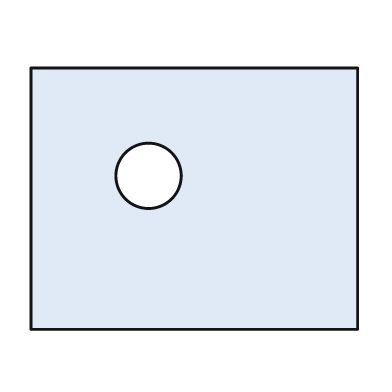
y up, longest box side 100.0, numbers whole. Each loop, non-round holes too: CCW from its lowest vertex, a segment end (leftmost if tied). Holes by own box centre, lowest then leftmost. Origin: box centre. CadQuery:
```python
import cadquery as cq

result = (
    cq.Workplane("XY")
    .moveTo(-50.0, -40.0)
    .lineTo(50.0, -40.0)
    .lineTo(50.0, 40.0)
    .lineTo(-50.0, 40.0)
    .close()
    .moveTo(-14.0, 7.0)
    .circle(10.0)
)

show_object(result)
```